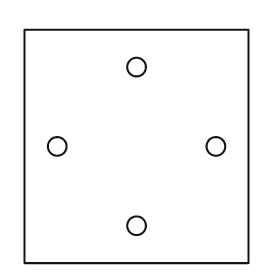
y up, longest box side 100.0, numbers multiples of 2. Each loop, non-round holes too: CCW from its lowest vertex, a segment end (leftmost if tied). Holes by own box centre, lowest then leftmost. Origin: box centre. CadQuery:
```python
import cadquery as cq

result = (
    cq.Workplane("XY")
    .moveTo(-48.0, -50.0)
    .lineTo(48.0, -50.0)
    .lineTo(48.0, 50.0)
    .lineTo(-48.0, 50.0)
    .close()
    .moveTo(0.0, -34.0)
    .circle(4.0)
    .moveTo(-34.0, 0.0)
    .circle(4.0)
    .moveTo(34.0, 0.0)
    .circle(4.0)
    .moveTo(0.0, 34.0)
    .circle(4.0)
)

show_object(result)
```